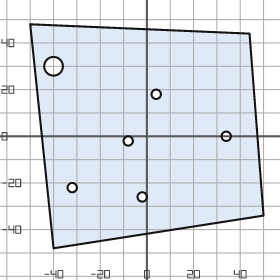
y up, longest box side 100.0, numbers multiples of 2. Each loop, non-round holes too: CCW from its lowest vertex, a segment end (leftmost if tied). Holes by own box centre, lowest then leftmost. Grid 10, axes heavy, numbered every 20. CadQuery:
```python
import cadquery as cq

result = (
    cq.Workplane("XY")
    .moveTo(-40.0, -48.0)
    .lineTo(50.0, -34.0)
    .lineTo(44.0, 44.0)
    .lineTo(-50.0, 48.0)
    .close()
    .moveTo(-2.0, -26.0)
    .circle(2.0)
    .moveTo(-32.0, -22.0)
    .circle(2.0)
    .moveTo(-8.0, -2.0)
    .circle(2.0)
    .moveTo(34.0, 0.0)
    .circle(2.0)
    .moveTo(4.0, 18.0)
    .circle(2.0)
    .moveTo(-40.0, 30.0)
    .circle(4.0)
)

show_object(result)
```